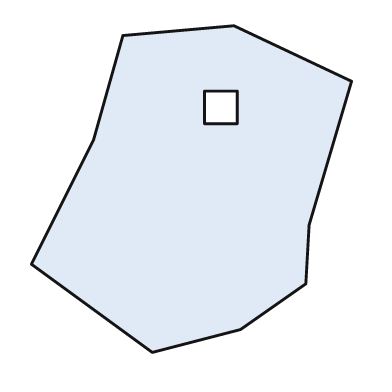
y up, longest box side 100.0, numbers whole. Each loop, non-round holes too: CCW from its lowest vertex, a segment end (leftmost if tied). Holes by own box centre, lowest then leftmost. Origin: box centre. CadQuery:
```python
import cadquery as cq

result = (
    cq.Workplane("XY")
    .moveTo(-12.0, -50.0)
    .lineTo(15.0, -43.0)
    .lineTo(35.0, -29.0)
    .lineTo(36.0, -11.0)
    .lineTo(49.0, 33.0)
    .lineTo(13.0, 50.0)
    .lineTo(-21.0, 47.0)
    .lineTo(-30.0, 15.0)
    .lineTo(-49.0, -23.0)
    .close()
    .moveTo(4.0, 20.0)
    .lineTo(14.0, 20.0)
    .lineTo(14.0, 30.0)
    .lineTo(4.0, 30.0)
    .close()
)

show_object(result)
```